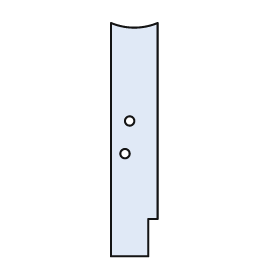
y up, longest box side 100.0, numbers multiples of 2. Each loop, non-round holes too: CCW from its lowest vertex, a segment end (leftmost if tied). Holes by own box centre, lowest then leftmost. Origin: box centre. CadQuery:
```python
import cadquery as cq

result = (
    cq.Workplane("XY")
    .moveTo(-10.0, -50.0)
    .lineTo(6.0, -50.0)
    .lineTo(6.0, -34.0)
    .lineTo(10.0, -34.0)
    .lineTo(10.0, 50.0)
    .threePointArc((0.0, 48.0), (-10.0, 50.0))
    .close()
    .moveTo(-4.0, -6.0)
    .circle(2.0)
    .moveTo(-2.0, 8.0)
    .circle(2.0)
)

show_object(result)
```